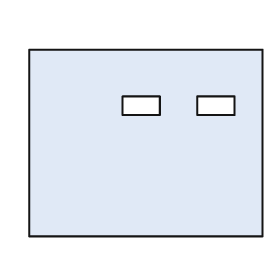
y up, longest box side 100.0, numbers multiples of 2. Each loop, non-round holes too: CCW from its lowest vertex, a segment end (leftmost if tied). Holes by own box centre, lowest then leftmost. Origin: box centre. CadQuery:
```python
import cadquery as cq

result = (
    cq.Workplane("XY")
    .moveTo(-50.0, -40.0)
    .lineTo(50.0, -40.0)
    .lineTo(50.0, 40.0)
    .lineTo(-50.0, 40.0)
    .close()
    .moveTo(-10.0, 12.0)
    .lineTo(6.0, 12.0)
    .lineTo(6.0, 20.0)
    .lineTo(-10.0, 20.0)
    .close()
    .moveTo(22.0, 12.0)
    .lineTo(38.0, 12.0)
    .lineTo(38.0, 20.0)
    .lineTo(22.0, 20.0)
    .close()
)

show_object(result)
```